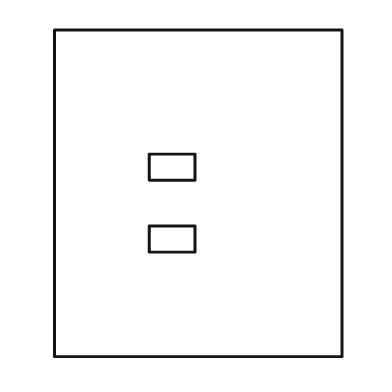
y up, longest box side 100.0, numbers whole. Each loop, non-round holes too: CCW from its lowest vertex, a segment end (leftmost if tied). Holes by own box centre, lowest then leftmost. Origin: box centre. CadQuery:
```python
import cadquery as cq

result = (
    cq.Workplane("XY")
    .moveTo(-44.0, -50.0)
    .lineTo(44.0, -50.0)
    .lineTo(44.0, 50.0)
    .lineTo(-44.0, 50.0)
    .close()
    .moveTo(-15.0, -18.0)
    .lineTo(-1.0, -18.0)
    .lineTo(-1.0, -10.0)
    .lineTo(-15.0, -10.0)
    .close()
    .moveTo(-15.0, 4.0)
    .lineTo(-1.0, 4.0)
    .lineTo(-1.0, 12.0)
    .lineTo(-15.0, 12.0)
    .close()
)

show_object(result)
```